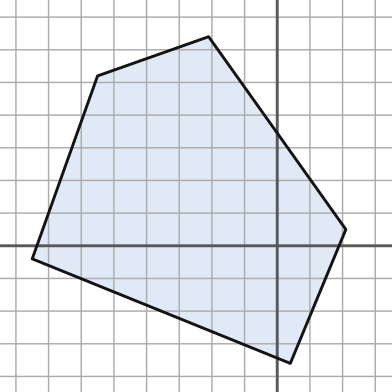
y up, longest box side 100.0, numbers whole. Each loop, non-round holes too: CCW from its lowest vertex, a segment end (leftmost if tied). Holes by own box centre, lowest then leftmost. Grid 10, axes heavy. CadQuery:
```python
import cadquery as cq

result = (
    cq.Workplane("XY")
    .moveTo(4.0, -36.0)
    .lineTo(21.0, 5.0)
    .lineTo(-21.0, 64.0)
    .lineTo(-55.0, 52.0)
    .lineTo(-75.0, -4.0)
    .close()
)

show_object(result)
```